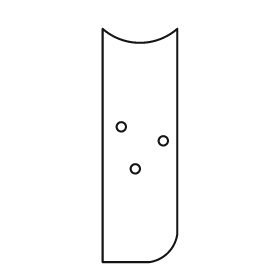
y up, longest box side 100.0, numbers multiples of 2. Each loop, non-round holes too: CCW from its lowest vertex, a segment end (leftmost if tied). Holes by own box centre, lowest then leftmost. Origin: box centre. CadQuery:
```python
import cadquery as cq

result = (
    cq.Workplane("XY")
    .moveTo(-16.0, -50.0)
    .lineTo(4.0, -50.0)
    .threePointArc((12.0, -46.0), (16.0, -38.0))
    .lineTo(16.0, 50.0)
    .threePointArc((0.0, 44.0), (-16.0, 50.0))
    .close()
    .moveTo(-2.0, -10.0)
    .circle(2.0)
    .moveTo(10.0, 2.0)
    .circle(2.0)
    .moveTo(-8.0, 8.0)
    .circle(2.0)
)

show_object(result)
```